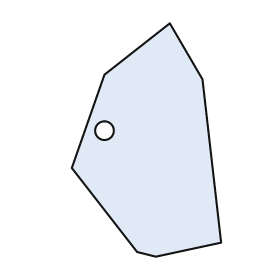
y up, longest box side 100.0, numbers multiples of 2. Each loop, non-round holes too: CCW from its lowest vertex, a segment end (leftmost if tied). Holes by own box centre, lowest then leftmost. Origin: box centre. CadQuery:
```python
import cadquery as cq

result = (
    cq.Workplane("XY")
    .moveTo(4.0, -50.0)
    .lineTo(32.0, -44.0)
    .lineTo(24.0, 26.0)
    .lineTo(10.0, 50.0)
    .lineTo(-18.0, 28.0)
    .lineTo(-32.0, -12.0)
    .lineTo(-4.0, -48.0)
    .close()
    .moveTo(-18.0, 4.0)
    .circle(4.0)
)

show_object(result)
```